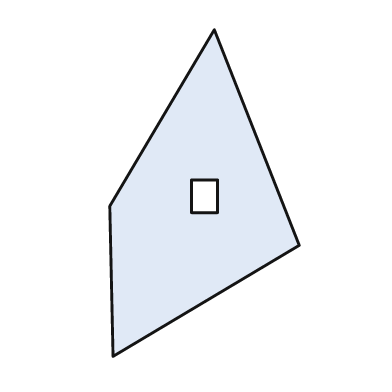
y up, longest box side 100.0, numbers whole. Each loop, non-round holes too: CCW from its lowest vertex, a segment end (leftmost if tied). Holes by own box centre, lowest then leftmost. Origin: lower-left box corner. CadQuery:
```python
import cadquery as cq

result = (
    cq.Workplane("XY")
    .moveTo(1.0, 0.0)
    .lineTo(58.0, 34.0)
    .lineTo(32.0, 100.0)
    .lineTo(0.0, 46.0)
    .close()
    .moveTo(25.0, 44.0)
    .lineTo(33.0, 44.0)
    .lineTo(33.0, 54.0)
    .lineTo(25.0, 54.0)
    .close()
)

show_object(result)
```